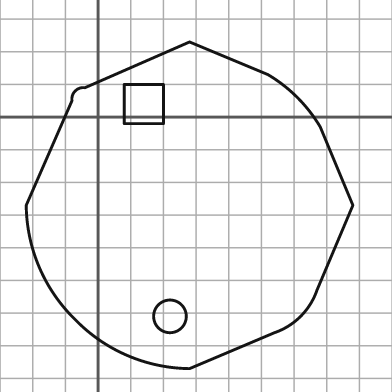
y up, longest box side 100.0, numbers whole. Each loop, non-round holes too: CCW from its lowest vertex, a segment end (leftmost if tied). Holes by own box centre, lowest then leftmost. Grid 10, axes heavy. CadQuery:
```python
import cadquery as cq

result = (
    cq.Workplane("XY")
    .moveTo(28.0, -77.0)
    .lineTo(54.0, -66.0)
    .threePointArc((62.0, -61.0), (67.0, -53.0))
    .lineTo(78.0, -27.0)
    .lineTo(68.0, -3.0)
    .threePointArc((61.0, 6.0), (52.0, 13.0))
    .lineTo(28.0, 23.0)
    .lineTo(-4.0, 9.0)
    .threePointArc((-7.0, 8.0), (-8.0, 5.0))
    .lineTo(-22.0, -27.0)
    .threePointArc((-18.0, -46.0), (-7.0, -62.0))
    .threePointArc((9.0, -73.0), (28.0, -77.0))
    .close()
    .moveTo(22.0, -61.0)
    .circle(5.0)
    .moveTo(8.0, -2.0)
    .lineTo(20.0, -2.0)
    .lineTo(20.0, 10.0)
    .lineTo(8.0, 10.0)
    .close()
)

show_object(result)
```